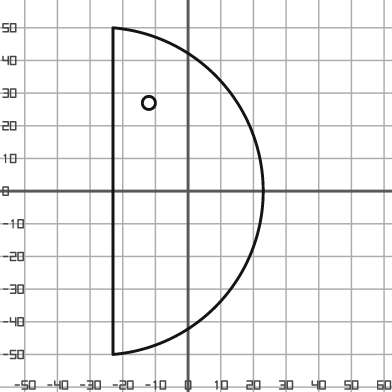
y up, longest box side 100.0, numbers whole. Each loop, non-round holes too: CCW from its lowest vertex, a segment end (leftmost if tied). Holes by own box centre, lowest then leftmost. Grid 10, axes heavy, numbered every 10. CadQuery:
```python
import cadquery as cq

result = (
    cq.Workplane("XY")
    .moveTo(-23.0, -50.0)
    .threePointArc((23.0, 0.0), (-23.0, 50.0))
    .close()
    .moveTo(-12.0, 27.0)
    .circle(2.0)
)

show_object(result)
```